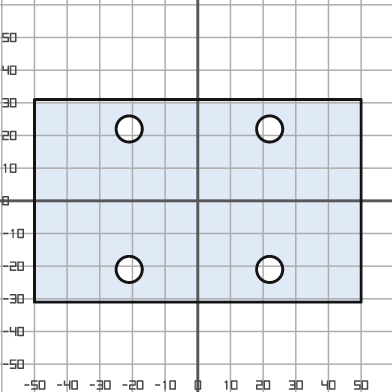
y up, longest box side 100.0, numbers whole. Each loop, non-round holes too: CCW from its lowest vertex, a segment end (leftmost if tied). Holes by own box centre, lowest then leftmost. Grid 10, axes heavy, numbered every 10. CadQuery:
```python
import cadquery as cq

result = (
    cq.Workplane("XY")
    .moveTo(-50.0, -31.0)
    .lineTo(50.0, -31.0)
    .lineTo(50.0, 31.0)
    .lineTo(-50.0, 31.0)
    .close()
    .moveTo(-21.0, -21.0)
    .circle(4.0)
    .moveTo(22.0, -21.0)
    .circle(4.0)
    .moveTo(-21.0, 22.0)
    .circle(4.0)
    .moveTo(22.0, 22.0)
    .circle(4.0)
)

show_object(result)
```